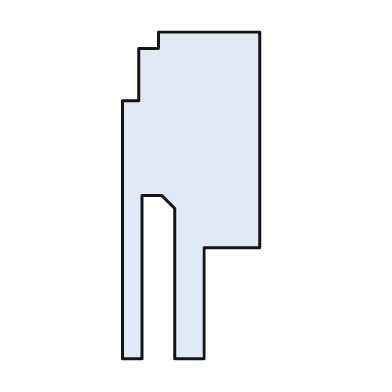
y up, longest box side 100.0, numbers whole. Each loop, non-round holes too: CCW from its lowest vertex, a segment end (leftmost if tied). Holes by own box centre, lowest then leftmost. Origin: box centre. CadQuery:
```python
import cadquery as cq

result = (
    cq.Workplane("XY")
    .moveTo(-21.0, -50.0)
    .lineTo(-15.0, -50.0)
    .lineTo(-15.0, 0.0)
    .lineTo(-9.0, 0.0)
    .lineTo(-5.0, -4.0)
    .lineTo(-5.0, -50.0)
    .lineTo(4.0, -50.0)
    .lineTo(4.0, -16.0)
    .lineTo(21.0, -16.0)
    .lineTo(21.0, 50.0)
    .lineTo(-10.0, 50.0)
    .lineTo(-10.0, 45.0)
    .lineTo(-16.0, 45.0)
    .lineTo(-16.0, 29.0)
    .lineTo(-21.0, 29.0)
    .close()
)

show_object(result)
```